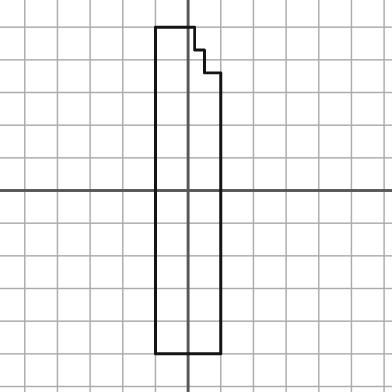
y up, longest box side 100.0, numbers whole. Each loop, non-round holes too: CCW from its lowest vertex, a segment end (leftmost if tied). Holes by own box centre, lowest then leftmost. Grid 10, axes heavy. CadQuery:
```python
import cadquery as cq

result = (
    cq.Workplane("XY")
    .moveTo(-10.0, -50.0)
    .lineTo(10.0, -50.0)
    .lineTo(10.0, 36.0)
    .lineTo(5.0, 36.0)
    .lineTo(5.0, 43.0)
    .lineTo(2.0, 43.0)
    .lineTo(2.0, 50.0)
    .lineTo(-10.0, 50.0)
    .close()
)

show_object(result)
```